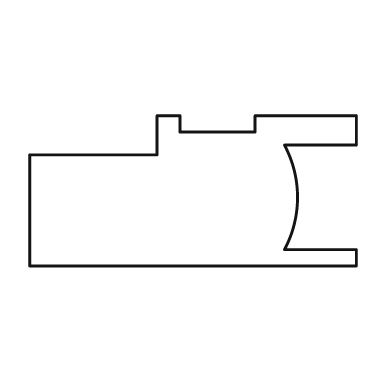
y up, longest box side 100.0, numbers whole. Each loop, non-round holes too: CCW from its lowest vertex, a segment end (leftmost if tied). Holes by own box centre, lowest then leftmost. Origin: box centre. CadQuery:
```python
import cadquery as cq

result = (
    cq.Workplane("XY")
    .moveTo(-50.0, -23.0)
    .lineTo(50.0, -23.0)
    .lineTo(50.0, -18.0)
    .lineTo(28.0, -18.0)
    .threePointArc((32.0, -2.0), (28.0, 14.0))
    .lineTo(50.0, 14.0)
    .lineTo(50.0, 23.0)
    .lineTo(19.0, 23.0)
    .lineTo(19.0, 18.0)
    .lineTo(-4.0, 18.0)
    .lineTo(-4.0, 23.0)
    .lineTo(-11.0, 23.0)
    .lineTo(-11.0, 11.0)
    .lineTo(-50.0, 11.0)
    .close()
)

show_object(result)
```